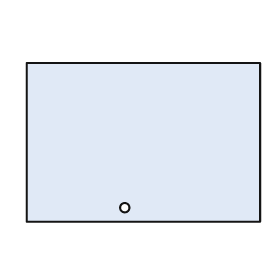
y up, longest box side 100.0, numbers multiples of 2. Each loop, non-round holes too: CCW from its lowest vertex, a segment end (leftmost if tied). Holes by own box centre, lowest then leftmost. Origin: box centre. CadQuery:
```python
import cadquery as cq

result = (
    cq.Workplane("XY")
    .moveTo(-50.0, -34.0)
    .lineTo(50.0, -34.0)
    .lineTo(50.0, 34.0)
    .lineTo(-50.0, 34.0)
    .close()
    .moveTo(-8.0, -28.0)
    .circle(2.0)
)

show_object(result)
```